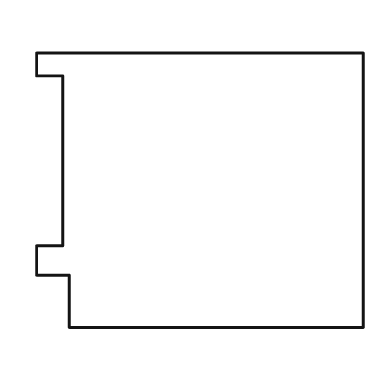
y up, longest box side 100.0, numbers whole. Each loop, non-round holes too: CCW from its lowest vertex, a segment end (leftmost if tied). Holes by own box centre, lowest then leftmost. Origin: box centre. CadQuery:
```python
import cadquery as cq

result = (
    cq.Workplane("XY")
    .moveTo(-40.0, -42.0)
    .lineTo(50.0, -42.0)
    .lineTo(50.0, 42.0)
    .lineTo(-50.0, 42.0)
    .lineTo(-50.0, 35.0)
    .lineTo(-42.0, 35.0)
    .lineTo(-42.0, -17.0)
    .lineTo(-50.0, -17.0)
    .lineTo(-50.0, -26.0)
    .lineTo(-40.0, -26.0)
    .close()
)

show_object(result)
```